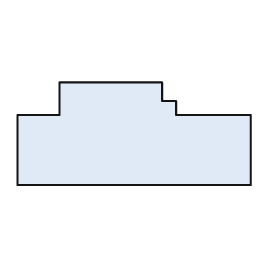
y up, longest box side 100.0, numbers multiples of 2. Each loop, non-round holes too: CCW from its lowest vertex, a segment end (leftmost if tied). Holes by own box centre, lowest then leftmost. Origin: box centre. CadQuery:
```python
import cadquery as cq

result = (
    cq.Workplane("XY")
    .moveTo(-50.0, -22.0)
    .lineTo(50.0, -22.0)
    .lineTo(50.0, 8.0)
    .lineTo(18.0, 8.0)
    .lineTo(18.0, 14.0)
    .lineTo(12.0, 14.0)
    .lineTo(12.0, 22.0)
    .lineTo(-32.0, 22.0)
    .lineTo(-32.0, 8.0)
    .lineTo(-50.0, 8.0)
    .close()
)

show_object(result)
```